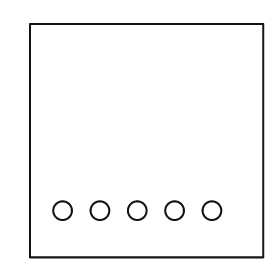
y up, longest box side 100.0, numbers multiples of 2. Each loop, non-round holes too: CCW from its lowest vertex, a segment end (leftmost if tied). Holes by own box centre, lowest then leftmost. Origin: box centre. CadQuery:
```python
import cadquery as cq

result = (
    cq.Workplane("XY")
    .moveTo(-50.0, -50.0)
    .lineTo(50.0, -50.0)
    .lineTo(50.0, 50.0)
    .lineTo(-50.0, 50.0)
    .close()
    .moveTo(-36.0, -30.0)
    .circle(4.0)
    .moveTo(-20.0, -30.0)
    .circle(4.0)
    .moveTo(-4.0, -30.0)
    .circle(4.0)
    .moveTo(12.0, -30.0)
    .circle(4.0)
    .moveTo(28.0, -30.0)
    .circle(4.0)
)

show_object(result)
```